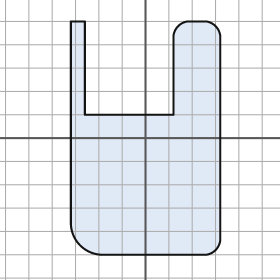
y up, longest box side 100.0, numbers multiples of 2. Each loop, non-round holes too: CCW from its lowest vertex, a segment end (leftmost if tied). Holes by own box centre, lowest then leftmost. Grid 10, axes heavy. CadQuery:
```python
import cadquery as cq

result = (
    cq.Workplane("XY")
    .moveTo(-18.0, -50.0)
    .lineTo(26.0, -50.0)
    .threePointArc((30.0, -48.0), (32.0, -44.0))
    .lineTo(32.0, 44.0)
    .threePointArc((30.0, 48.0), (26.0, 50.0))
    .lineTo(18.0, 50.0)
    .threePointArc((14.0, 48.0), (12.0, 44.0))
    .lineTo(12.0, 10.0)
    .lineTo(-26.0, 10.0)
    .lineTo(-26.0, 50.0)
    .lineTo(-32.0, 50.0)
    .lineTo(-32.0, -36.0)
    .threePointArc((-28.0, -46.0), (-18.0, -50.0))
    .close()
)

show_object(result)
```